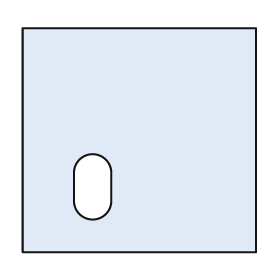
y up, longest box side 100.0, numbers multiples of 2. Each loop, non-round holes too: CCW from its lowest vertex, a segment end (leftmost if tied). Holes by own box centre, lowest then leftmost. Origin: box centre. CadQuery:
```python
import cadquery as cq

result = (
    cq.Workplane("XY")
    .moveTo(-50.0, -48.0)
    .lineTo(50.0, -48.0)
    .lineTo(50.0, 48.0)
    .lineTo(-50.0, 48.0)
    .close()
    .moveTo(-28.0, -26.0)
    .threePointArc((-20.0, -34.0), (-12.0, -26.0))
    .lineTo(-12.0, -14.0)
    .threePointArc((-20.0, -6.0), (-28.0, -14.0))
    .close()
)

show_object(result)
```